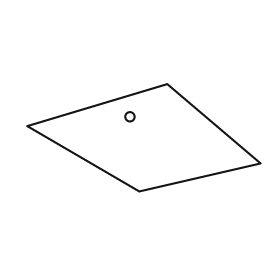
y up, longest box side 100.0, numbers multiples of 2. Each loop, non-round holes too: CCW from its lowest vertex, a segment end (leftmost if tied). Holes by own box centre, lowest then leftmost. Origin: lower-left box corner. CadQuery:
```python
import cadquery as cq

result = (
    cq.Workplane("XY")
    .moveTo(48.0, 0.0)
    .lineTo(100.0, 12.0)
    .lineTo(60.0, 46.0)
    .lineTo(0.0, 28.0)
    .close()
    .moveTo(44.0, 32.0)
    .circle(2.0)
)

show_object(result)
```